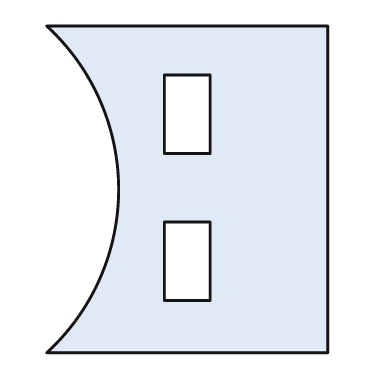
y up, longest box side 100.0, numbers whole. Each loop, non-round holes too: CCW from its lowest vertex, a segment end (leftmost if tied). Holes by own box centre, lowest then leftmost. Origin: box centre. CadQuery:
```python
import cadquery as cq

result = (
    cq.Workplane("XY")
    .moveTo(-43.0, -50.0)
    .lineTo(43.0, -50.0)
    .lineTo(43.0, 50.0)
    .lineTo(-43.0, 50.0)
    .threePointArc((-21.0, 0.0), (-43.0, -50.0))
    .close()
    .moveTo(-7.0, -34.0)
    .lineTo(7.0, -34.0)
    .lineTo(7.0, -10.0)
    .lineTo(-7.0, -10.0)
    .close()
    .moveTo(-7.0, 11.0)
    .lineTo(7.0, 11.0)
    .lineTo(7.0, 35.0)
    .lineTo(-7.0, 35.0)
    .close()
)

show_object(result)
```